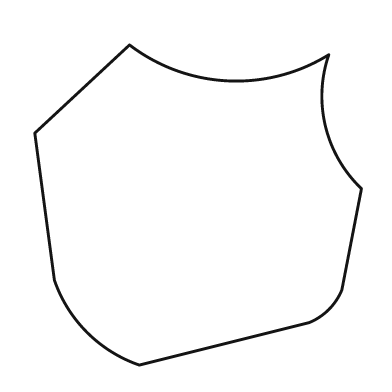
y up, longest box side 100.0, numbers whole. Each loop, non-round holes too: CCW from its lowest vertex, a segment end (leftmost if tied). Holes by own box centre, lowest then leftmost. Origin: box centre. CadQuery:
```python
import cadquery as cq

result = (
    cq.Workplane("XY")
    .moveTo(-18.0, -49.0)
    .lineTo(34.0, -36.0)
    .threePointArc((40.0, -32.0), (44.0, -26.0))
    .lineTo(50.0, 5.0)
    .threePointArc((39.0, 24.0), (40.0, 46.0))
    .threePointArc((9.0, 38.0), (-21.0, 49.0))
    .lineTo(-50.0, 22.0)
    .lineTo(-44.0, -23.0)
    .threePointArc((-34.0, -39.0), (-18.0, -49.0))
    .close()
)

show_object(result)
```